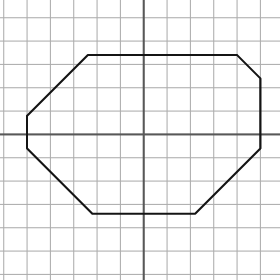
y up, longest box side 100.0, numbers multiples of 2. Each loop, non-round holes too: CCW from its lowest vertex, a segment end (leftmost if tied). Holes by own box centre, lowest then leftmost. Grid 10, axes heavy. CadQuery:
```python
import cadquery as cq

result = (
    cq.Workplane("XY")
    .moveTo(-22.0, -34.0)
    .lineTo(22.0, -34.0)
    .lineTo(50.0, -6.0)
    .lineTo(50.0, 24.0)
    .lineTo(40.0, 34.0)
    .lineTo(-24.0, 34.0)
    .lineTo(-50.0, 8.0)
    .lineTo(-50.0, -6.0)
    .close()
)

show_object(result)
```